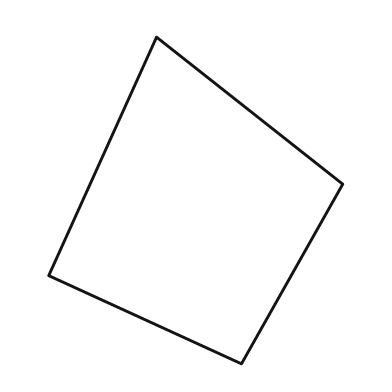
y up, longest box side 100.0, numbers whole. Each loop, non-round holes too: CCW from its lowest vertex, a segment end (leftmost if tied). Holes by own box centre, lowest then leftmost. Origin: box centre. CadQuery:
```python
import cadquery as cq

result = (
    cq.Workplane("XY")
    .moveTo(14.0, -50.0)
    .lineTo(45.0, 5.0)
    .lineTo(-12.0, 50.0)
    .lineTo(-45.0, -23.0)
    .close()
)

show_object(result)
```